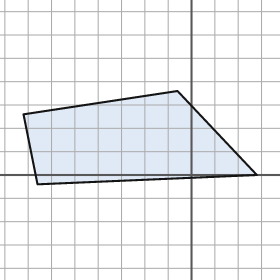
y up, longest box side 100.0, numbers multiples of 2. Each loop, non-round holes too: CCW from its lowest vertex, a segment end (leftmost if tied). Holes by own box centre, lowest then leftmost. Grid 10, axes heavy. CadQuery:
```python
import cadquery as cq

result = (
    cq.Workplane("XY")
    .moveTo(-66.0, -4.0)
    .lineTo(28.0, 0.0)
    .lineTo(-6.0, 36.0)
    .lineTo(-72.0, 26.0)
    .close()
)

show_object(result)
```